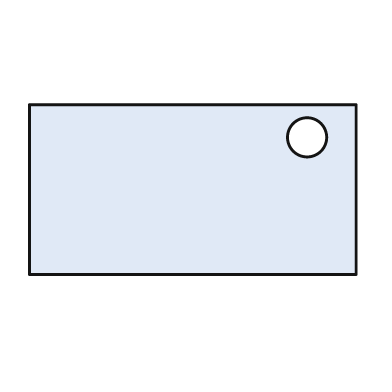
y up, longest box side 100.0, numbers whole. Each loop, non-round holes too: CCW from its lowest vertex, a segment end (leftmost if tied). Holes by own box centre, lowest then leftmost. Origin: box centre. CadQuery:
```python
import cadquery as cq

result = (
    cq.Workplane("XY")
    .moveTo(-50.0, -26.0)
    .lineTo(50.0, -26.0)
    .lineTo(50.0, 26.0)
    .lineTo(-50.0, 26.0)
    .close()
    .moveTo(35.0, 16.0)
    .circle(6.0)
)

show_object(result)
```